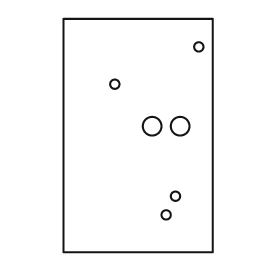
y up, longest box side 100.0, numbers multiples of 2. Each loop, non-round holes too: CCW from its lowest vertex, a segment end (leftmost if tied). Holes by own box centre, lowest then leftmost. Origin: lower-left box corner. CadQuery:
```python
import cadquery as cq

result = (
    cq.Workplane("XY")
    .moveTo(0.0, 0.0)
    .lineTo(64.0, 0.0)
    .lineTo(64.0, 100.0)
    .lineTo(0.0, 100.0)
    .close()
    .moveTo(44.0, 16.0)
    .circle(2.0)
    .moveTo(48.0, 24.0)
    .circle(2.0)
    .moveTo(38.0, 54.0)
    .circle(4.0)
    .moveTo(50.0, 54.0)
    .circle(4.0)
    .moveTo(22.0, 72.0)
    .circle(2.0)
    .moveTo(58.0, 88.0)
    .circle(2.0)
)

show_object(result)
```